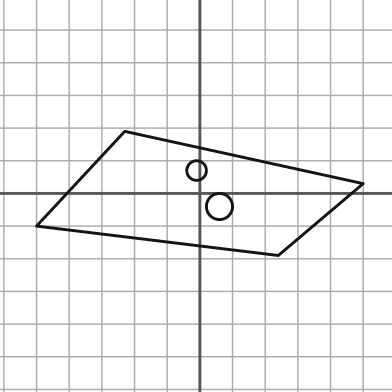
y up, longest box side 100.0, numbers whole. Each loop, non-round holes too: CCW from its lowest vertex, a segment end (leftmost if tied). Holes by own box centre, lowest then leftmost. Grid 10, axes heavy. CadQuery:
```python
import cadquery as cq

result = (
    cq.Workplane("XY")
    .moveTo(24.0, -19.0)
    .lineTo(50.0, 3.0)
    .lineTo(-23.0, 19.0)
    .lineTo(-50.0, -10.0)
    .close()
    .moveTo(6.0, -4.0)
    .circle(4.0)
    .moveTo(-1.0, 7.0)
    .circle(3.0)
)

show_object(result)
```